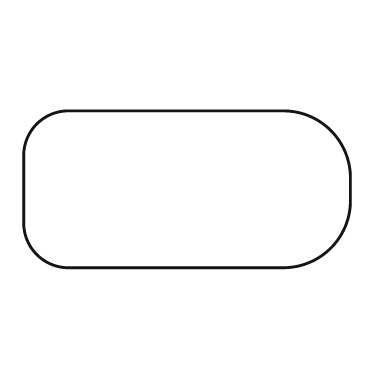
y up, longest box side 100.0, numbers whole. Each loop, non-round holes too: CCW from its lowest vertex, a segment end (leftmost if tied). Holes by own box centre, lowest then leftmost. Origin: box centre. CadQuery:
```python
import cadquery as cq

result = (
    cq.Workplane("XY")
    .moveTo(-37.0, -24.0)
    .lineTo(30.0, -24.0)
    .threePointArc((44.0, -18.0), (50.0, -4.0))
    .lineTo(50.0, 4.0)
    .threePointArc((44.0, 18.0), (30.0, 24.0))
    .lineTo(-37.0, 24.0)
    .threePointArc((-46.0, 20.0), (-50.0, 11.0))
    .lineTo(-50.0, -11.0)
    .threePointArc((-46.0, -20.0), (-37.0, -24.0))
    .close()
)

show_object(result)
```